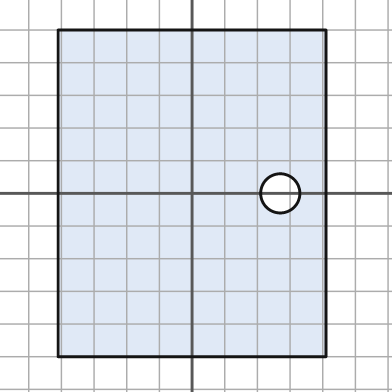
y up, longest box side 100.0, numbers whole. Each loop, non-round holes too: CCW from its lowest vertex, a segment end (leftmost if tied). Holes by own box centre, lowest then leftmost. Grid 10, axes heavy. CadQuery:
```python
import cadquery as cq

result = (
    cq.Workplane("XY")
    .moveTo(-41.0, -50.0)
    .lineTo(41.0, -50.0)
    .lineTo(41.0, 50.0)
    .lineTo(-41.0, 50.0)
    .close()
    .moveTo(27.0, 0.0)
    .circle(6.0)
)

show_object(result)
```